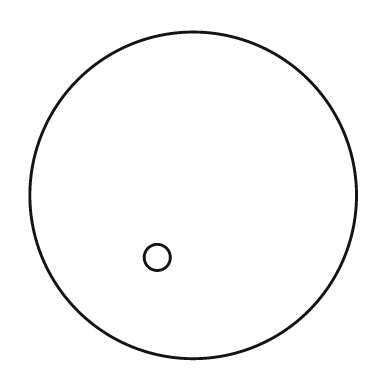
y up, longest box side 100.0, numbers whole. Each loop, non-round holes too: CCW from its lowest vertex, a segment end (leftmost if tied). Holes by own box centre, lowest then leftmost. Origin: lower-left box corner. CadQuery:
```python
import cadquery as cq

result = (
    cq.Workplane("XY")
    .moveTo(50.0, 50.0)
    .circle(50.0)
    .moveTo(39.0, 31.0)
    .circle(4.0)
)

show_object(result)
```